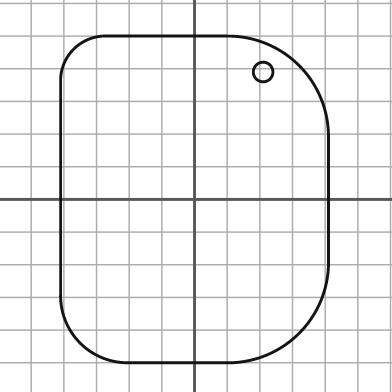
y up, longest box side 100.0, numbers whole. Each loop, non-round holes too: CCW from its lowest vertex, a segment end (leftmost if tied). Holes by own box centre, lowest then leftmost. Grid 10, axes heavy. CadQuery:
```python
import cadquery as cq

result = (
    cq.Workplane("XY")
    .moveTo(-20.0, -50.0)
    .lineTo(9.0, -50.0)
    .threePointArc((32.0, -41.0), (41.0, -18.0))
    .lineTo(41.0, 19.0)
    .threePointArc((32.0, 41.0), (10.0, 50.0))
    .lineTo(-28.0, 50.0)
    .threePointArc((-37.0, 46.0), (-41.0, 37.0))
    .lineTo(-41.0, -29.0)
    .threePointArc((-35.0, -44.0), (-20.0, -50.0))
    .close()
    .moveTo(21.0, 39.0)
    .circle(3.0)
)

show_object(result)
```